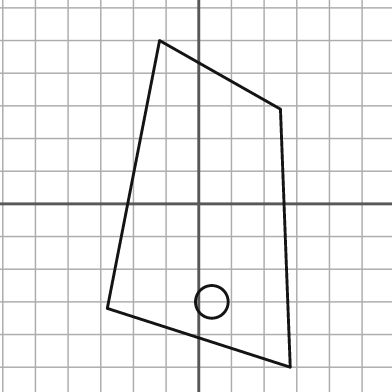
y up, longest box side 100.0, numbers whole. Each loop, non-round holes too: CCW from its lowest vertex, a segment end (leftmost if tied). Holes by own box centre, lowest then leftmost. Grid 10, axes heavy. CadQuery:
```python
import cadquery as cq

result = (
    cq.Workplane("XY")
    .moveTo(28.0, -50.0)
    .lineTo(25.0, 29.0)
    .lineTo(-12.0, 50.0)
    .lineTo(-28.0, -32.0)
    .close()
    .moveTo(4.0, -30.0)
    .circle(5.0)
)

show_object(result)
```